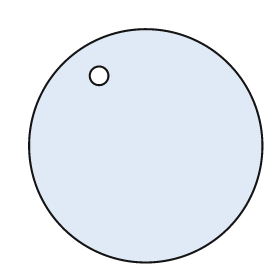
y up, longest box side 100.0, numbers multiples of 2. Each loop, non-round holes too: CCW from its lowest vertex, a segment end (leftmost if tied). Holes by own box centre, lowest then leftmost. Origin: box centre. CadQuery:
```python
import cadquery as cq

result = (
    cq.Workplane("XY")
    .moveTo(0.0, 0.0)
    .circle(50.0)
    .moveTo(-20.0, 30.0)
    .circle(4.0)
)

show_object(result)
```